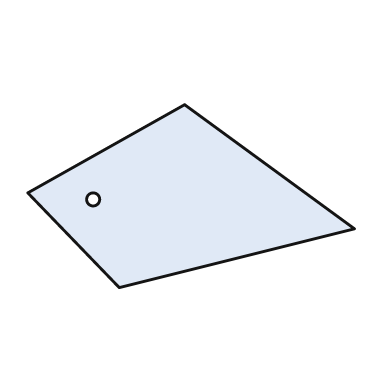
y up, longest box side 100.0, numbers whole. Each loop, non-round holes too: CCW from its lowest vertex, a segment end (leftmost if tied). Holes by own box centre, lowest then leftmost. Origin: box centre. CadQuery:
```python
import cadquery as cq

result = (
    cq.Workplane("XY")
    .moveTo(-22.0, -28.0)
    .lineTo(50.0, -10.0)
    .lineTo(-2.0, 28.0)
    .lineTo(-50.0, 1.0)
    .close()
    .moveTo(-30.0, -1.0)
    .circle(2.0)
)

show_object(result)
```